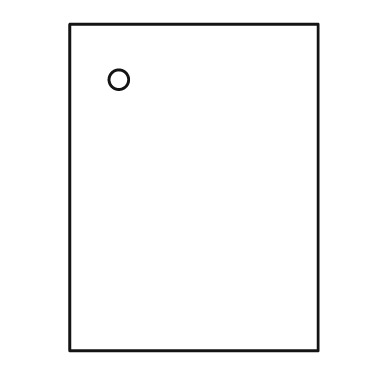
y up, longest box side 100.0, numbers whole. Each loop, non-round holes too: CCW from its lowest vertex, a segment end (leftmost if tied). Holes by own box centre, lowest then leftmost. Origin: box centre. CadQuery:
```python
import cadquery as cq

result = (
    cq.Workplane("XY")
    .moveTo(-38.0, -50.0)
    .lineTo(38.0, -50.0)
    .lineTo(38.0, 50.0)
    .lineTo(-38.0, 50.0)
    .close()
    .moveTo(-23.0, 33.0)
    .circle(3.0)
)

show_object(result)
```